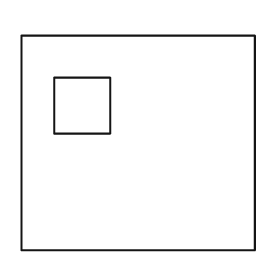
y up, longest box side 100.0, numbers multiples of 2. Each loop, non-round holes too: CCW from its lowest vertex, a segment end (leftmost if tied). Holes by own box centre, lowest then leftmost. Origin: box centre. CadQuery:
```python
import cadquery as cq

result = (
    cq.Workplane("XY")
    .moveTo(-50.0, -46.0)
    .lineTo(50.0, -46.0)
    .lineTo(50.0, 46.0)
    .lineTo(-50.0, 46.0)
    .close()
    .moveTo(-36.0, 4.0)
    .lineTo(-12.0, 4.0)
    .lineTo(-12.0, 28.0)
    .lineTo(-36.0, 28.0)
    .close()
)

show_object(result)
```